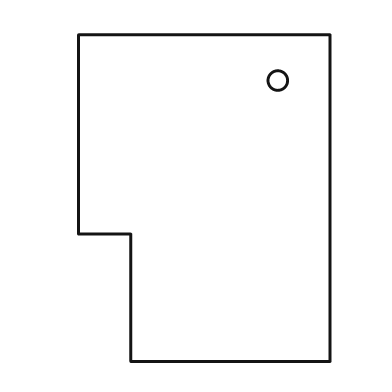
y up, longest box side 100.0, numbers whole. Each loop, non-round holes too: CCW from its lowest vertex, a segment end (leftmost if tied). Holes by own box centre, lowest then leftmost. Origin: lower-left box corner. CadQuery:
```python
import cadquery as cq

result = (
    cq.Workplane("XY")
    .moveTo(16.0, 0.0)
    .lineTo(77.0, 0.0)
    .lineTo(77.0, 100.0)
    .lineTo(0.0, 100.0)
    .lineTo(0.0, 39.0)
    .lineTo(16.0, 39.0)
    .close()
    .moveTo(61.0, 86.0)
    .circle(3.0)
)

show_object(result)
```